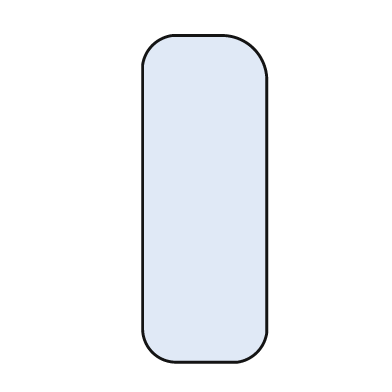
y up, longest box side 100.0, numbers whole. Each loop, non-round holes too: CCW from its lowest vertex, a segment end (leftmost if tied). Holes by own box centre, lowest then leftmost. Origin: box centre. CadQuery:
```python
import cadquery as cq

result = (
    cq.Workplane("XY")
    .moveTo(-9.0, -50.0)
    .lineTo(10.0, -50.0)
    .threePointArc((16.0, -47.0), (19.0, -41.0))
    .lineTo(19.0, 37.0)
    .threePointArc((15.0, 46.0), (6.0, 50.0))
    .lineTo(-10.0, 50.0)
    .threePointArc((-16.0, 47.0), (-19.0, 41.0))
    .lineTo(-19.0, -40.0)
    .threePointArc((-16.0, -47.0), (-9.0, -50.0))
    .close()
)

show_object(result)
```